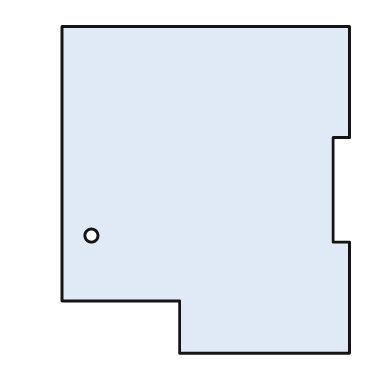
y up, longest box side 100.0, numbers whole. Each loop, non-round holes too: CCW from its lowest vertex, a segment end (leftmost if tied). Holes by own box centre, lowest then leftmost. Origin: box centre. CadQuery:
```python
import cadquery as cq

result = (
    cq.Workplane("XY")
    .moveTo(-8.0, -50.0)
    .lineTo(44.0, -50.0)
    .lineTo(44.0, -16.0)
    .lineTo(39.0, -16.0)
    .lineTo(39.0, 16.0)
    .lineTo(44.0, 16.0)
    .lineTo(44.0, 50.0)
    .lineTo(-44.0, 50.0)
    .lineTo(-44.0, -34.0)
    .lineTo(-8.0, -34.0)
    .close()
    .moveTo(-35.0, -14.0)
    .circle(2.0)
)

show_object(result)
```